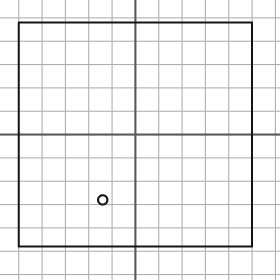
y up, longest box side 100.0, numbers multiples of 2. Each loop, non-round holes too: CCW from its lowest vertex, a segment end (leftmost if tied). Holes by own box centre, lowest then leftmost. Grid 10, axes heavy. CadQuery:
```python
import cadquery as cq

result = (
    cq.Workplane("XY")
    .moveTo(-50.0, -48.0)
    .lineTo(50.0, -48.0)
    .lineTo(50.0, 48.0)
    .lineTo(-50.0, 48.0)
    .close()
    .moveTo(-14.0, -28.0)
    .circle(2.0)
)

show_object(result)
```